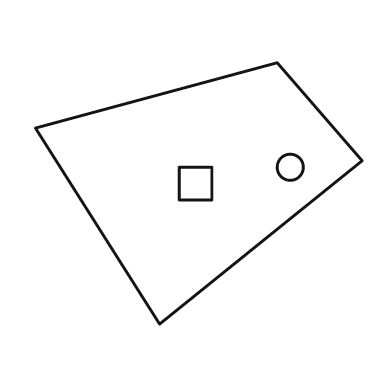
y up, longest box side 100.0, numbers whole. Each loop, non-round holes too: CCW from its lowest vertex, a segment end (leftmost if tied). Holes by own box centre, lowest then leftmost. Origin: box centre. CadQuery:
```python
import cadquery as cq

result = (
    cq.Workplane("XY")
    .moveTo(-12.0, -40.0)
    .lineTo(50.0, 10.0)
    .lineTo(24.0, 40.0)
    .lineTo(-50.0, 20.0)
    .close()
    .moveTo(-6.0, -2.0)
    .lineTo(4.0, -2.0)
    .lineTo(4.0, 8.0)
    .lineTo(-6.0, 8.0)
    .close()
    .moveTo(28.0, 8.0)
    .circle(4.0)
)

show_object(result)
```